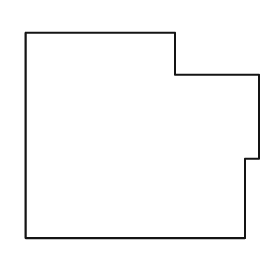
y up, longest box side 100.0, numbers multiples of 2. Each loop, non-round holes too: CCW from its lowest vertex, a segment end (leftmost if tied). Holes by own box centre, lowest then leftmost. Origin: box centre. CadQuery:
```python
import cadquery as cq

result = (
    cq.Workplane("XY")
    .moveTo(-50.0, -44.0)
    .lineTo(44.0, -44.0)
    .lineTo(44.0, -10.0)
    .lineTo(50.0, -10.0)
    .lineTo(50.0, 26.0)
    .lineTo(14.0, 26.0)
    .lineTo(14.0, 44.0)
    .lineTo(-50.0, 44.0)
    .close()
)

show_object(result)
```